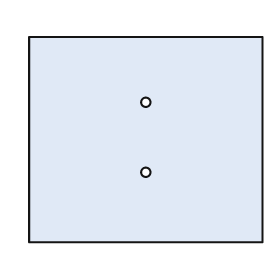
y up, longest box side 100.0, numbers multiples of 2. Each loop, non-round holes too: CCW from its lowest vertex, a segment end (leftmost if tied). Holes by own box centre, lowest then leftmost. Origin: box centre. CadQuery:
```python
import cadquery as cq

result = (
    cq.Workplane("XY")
    .moveTo(-50.0, -44.0)
    .lineTo(50.0, -44.0)
    .lineTo(50.0, 44.0)
    .lineTo(-50.0, 44.0)
    .close()
    .moveTo(0.0, -14.0)
    .circle(2.0)
    .moveTo(0.0, 16.0)
    .circle(2.0)
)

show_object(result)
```